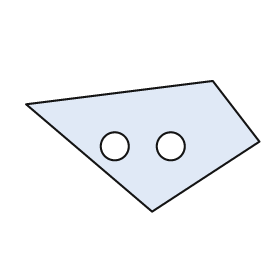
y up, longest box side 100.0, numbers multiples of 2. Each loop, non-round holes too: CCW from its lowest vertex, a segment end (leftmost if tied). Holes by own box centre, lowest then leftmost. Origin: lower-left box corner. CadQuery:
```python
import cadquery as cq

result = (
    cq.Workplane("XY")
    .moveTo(54.0, 0.0)
    .lineTo(100.0, 30.0)
    .lineTo(80.0, 56.0)
    .lineTo(0.0, 46.0)
    .close()
    .moveTo(38.0, 28.0)
    .circle(6.0)
    .moveTo(62.0, 28.0)
    .circle(6.0)
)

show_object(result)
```